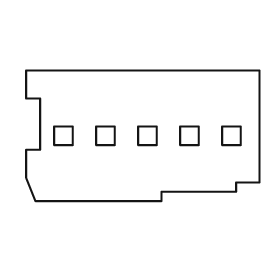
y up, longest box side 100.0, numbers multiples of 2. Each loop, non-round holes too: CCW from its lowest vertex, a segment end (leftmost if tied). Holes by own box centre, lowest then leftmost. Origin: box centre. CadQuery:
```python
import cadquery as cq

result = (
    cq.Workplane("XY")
    .moveTo(-46.0, -28.0)
    .lineTo(8.0, -28.0)
    .lineTo(8.0, -24.0)
    .lineTo(40.0, -24.0)
    .lineTo(40.0, -20.0)
    .lineTo(50.0, -20.0)
    .lineTo(50.0, 28.0)
    .lineTo(-50.0, 28.0)
    .lineTo(-50.0, 16.0)
    .lineTo(-44.0, 16.0)
    .lineTo(-44.0, -6.0)
    .lineTo(-50.0, -6.0)
    .lineTo(-50.0, -18.0)
    .close()
    .moveTo(-38.0, -4.0)
    .lineTo(-30.0, -4.0)
    .lineTo(-30.0, 4.0)
    .lineTo(-38.0, 4.0)
    .close()
    .moveTo(-20.0, -4.0)
    .lineTo(-12.0, -4.0)
    .lineTo(-12.0, 4.0)
    .lineTo(-20.0, 4.0)
    .close()
    .moveTo(-2.0, -4.0)
    .lineTo(6.0, -4.0)
    .lineTo(6.0, 4.0)
    .lineTo(-2.0, 4.0)
    .close()
    .moveTo(16.0, -4.0)
    .lineTo(24.0, -4.0)
    .lineTo(24.0, 4.0)
    .lineTo(16.0, 4.0)
    .close()
    .moveTo(34.0, -4.0)
    .lineTo(42.0, -4.0)
    .lineTo(42.0, 4.0)
    .lineTo(34.0, 4.0)
    .close()
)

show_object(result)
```